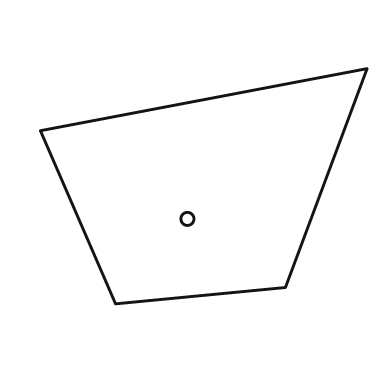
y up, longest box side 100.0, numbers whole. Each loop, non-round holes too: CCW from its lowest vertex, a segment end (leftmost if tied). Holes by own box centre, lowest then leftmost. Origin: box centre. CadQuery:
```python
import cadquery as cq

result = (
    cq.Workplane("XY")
    .moveTo(-27.0, -36.0)
    .lineTo(25.0, -31.0)
    .lineTo(50.0, 36.0)
    .lineTo(-50.0, 17.0)
    .close()
    .moveTo(-5.0, -10.0)
    .circle(2.0)
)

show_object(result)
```